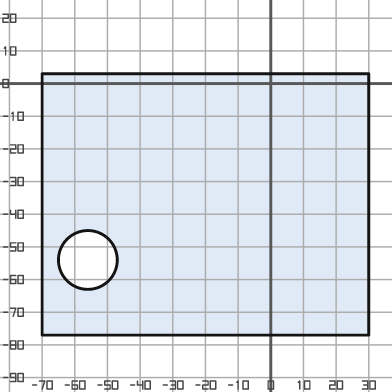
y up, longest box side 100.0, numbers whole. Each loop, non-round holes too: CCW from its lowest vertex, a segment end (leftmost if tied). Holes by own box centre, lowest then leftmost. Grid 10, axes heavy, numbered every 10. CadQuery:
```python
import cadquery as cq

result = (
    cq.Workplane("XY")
    .moveTo(-70.0, -77.0)
    .lineTo(30.0, -77.0)
    .lineTo(30.0, 3.0)
    .lineTo(-70.0, 3.0)
    .close()
    .moveTo(-56.0, -54.0)
    .circle(9.0)
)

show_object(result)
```